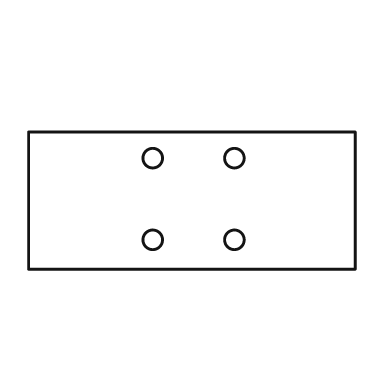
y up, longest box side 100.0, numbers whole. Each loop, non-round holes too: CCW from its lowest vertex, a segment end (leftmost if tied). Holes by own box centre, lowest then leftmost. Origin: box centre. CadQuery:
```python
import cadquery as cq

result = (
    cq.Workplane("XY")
    .moveTo(-50.0, -21.0)
    .lineTo(50.0, -21.0)
    .lineTo(50.0, 21.0)
    .lineTo(-50.0, 21.0)
    .close()
    .moveTo(-12.0, -12.0)
    .circle(3.0)
    .moveTo(13.0, -12.0)
    .circle(3.0)
    .moveTo(-12.0, 13.0)
    .circle(3.0)
    .moveTo(13.0, 13.0)
    .circle(3.0)
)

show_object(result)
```